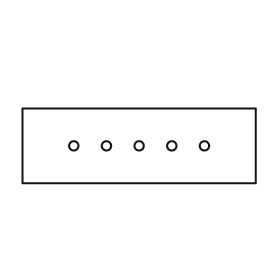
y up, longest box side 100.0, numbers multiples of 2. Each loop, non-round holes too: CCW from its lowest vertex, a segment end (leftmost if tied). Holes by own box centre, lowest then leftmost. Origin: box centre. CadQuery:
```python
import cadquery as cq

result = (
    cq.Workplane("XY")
    .moveTo(-50.0, -16.0)
    .lineTo(50.0, -16.0)
    .lineTo(50.0, 16.0)
    .lineTo(-50.0, 16.0)
    .close()
    .moveTo(-28.0, 0.0)
    .circle(2.0)
    .moveTo(-14.0, 0.0)
    .circle(2.0)
    .moveTo(0.0, 0.0)
    .circle(2.0)
    .moveTo(14.0, 0.0)
    .circle(2.0)
    .moveTo(28.0, 0.0)
    .circle(2.0)
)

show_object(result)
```